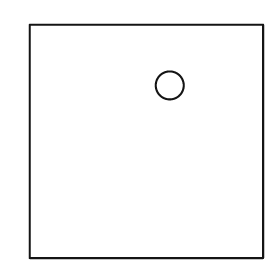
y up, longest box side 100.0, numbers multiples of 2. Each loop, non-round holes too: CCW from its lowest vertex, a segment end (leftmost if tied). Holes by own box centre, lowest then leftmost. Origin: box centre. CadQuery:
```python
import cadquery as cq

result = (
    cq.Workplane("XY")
    .moveTo(-50.0, -50.0)
    .lineTo(50.0, -50.0)
    .lineTo(50.0, 50.0)
    .lineTo(-50.0, 50.0)
    .close()
    .moveTo(10.0, 24.0)
    .circle(6.0)
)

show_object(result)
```